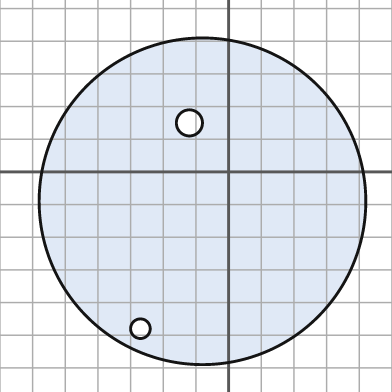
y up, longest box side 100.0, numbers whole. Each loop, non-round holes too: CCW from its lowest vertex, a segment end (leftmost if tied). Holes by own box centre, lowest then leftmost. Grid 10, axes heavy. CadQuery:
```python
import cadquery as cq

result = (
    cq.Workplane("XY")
    .moveTo(-8.0, -9.0)
    .circle(50.0)
    .moveTo(-27.0, -48.0)
    .circle(3.0)
    .moveTo(-12.0, 15.0)
    .circle(4.0)
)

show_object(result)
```